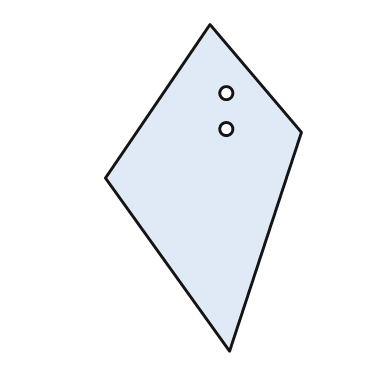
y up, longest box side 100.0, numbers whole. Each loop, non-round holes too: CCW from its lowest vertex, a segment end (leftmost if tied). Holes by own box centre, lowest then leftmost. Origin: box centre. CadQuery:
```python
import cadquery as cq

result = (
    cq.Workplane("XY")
    .moveTo(8.0, -50.0)
    .lineTo(30.0, 17.0)
    .lineTo(2.0, 50.0)
    .lineTo(-30.0, 3.0)
    .close()
    .moveTo(7.0, 18.0)
    .circle(2.0)
    .moveTo(7.0, 29.0)
    .circle(2.0)
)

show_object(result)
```